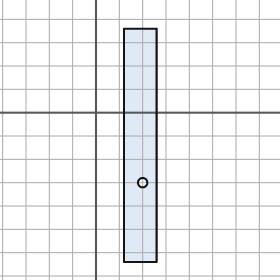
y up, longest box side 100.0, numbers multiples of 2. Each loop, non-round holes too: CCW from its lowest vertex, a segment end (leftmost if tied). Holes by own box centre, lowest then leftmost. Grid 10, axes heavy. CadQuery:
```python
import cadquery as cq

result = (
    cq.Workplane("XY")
    .moveTo(12.0, -64.0)
    .lineTo(26.0, -64.0)
    .lineTo(26.0, 36.0)
    .lineTo(12.0, 36.0)
    .close()
    .moveTo(20.0, -30.0)
    .circle(2.0)
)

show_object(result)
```